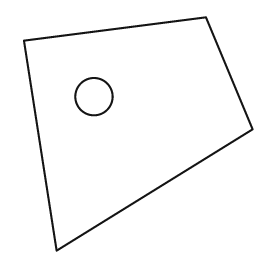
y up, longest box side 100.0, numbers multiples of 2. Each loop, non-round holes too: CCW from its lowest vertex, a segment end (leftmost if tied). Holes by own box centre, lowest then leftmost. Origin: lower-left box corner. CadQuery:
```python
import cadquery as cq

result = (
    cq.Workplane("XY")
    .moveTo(14.0, 0.0)
    .lineTo(98.0, 52.0)
    .lineTo(78.0, 100.0)
    .lineTo(0.0, 90.0)
    .close()
    .moveTo(30.0, 66.0)
    .circle(8.0)
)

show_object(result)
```